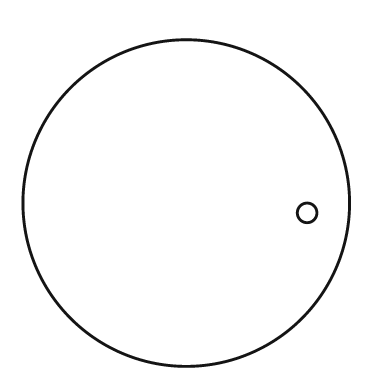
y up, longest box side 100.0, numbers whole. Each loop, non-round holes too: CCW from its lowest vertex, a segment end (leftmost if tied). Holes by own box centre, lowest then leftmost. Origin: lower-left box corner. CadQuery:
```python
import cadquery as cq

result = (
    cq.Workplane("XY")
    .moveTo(50.0, 50.0)
    .circle(50.0)
    .moveTo(87.0, 47.0)
    .circle(3.0)
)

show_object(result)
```